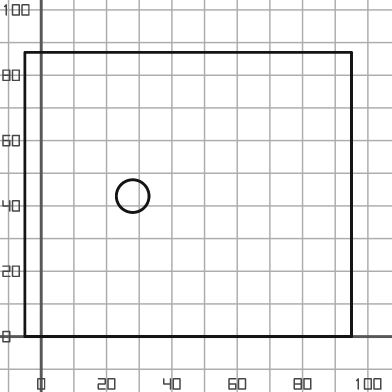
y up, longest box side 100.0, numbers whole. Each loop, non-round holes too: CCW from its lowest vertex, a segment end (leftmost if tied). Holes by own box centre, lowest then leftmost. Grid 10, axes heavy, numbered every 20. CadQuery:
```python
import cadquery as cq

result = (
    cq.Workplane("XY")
    .moveTo(-5.0, 0.0)
    .lineTo(95.0, 0.0)
    .lineTo(95.0, 87.0)
    .lineTo(-5.0, 87.0)
    .close()
    .moveTo(28.0, 43.0)
    .circle(5.0)
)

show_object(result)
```